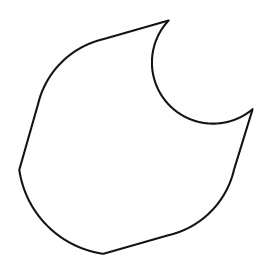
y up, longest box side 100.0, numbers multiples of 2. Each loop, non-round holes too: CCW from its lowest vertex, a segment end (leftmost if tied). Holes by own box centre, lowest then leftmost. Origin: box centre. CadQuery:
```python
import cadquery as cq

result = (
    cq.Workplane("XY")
    .moveTo(-14.0, -50.0)
    .lineTo(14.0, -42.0)
    .threePointArc((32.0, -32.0), (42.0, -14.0))
    .lineTo(50.0, 12.0)
    .threePointArc((14.0, 14.0), (14.0, 50.0))
    .lineTo(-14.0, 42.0)
    .threePointArc((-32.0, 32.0), (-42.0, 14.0))
    .lineTo(-50.0, -14.0)
    .threePointArc((-38.0, -38.0), (-14.0, -50.0))
    .close()
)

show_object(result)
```